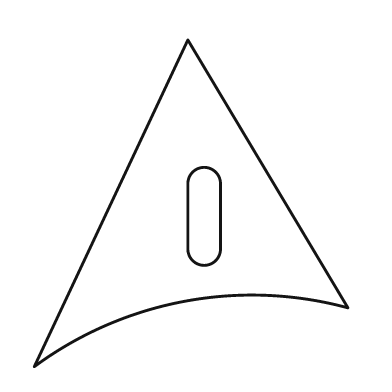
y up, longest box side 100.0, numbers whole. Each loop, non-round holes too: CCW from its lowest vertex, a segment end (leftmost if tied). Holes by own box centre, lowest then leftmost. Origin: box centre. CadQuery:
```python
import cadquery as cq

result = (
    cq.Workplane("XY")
    .moveTo(-48.0, -50.0)
    .threePointArc((-2.0, -30.0), (48.0, -32.0))
    .lineTo(-1.0, 50.0)
    .close()
    .moveTo(-1.0, -14.0)
    .threePointArc((4.0, -19.0), (9.0, -14.0))
    .lineTo(9.0, 6.0)
    .threePointArc((4.0, 11.0), (-1.0, 6.0))
    .close()
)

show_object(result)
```